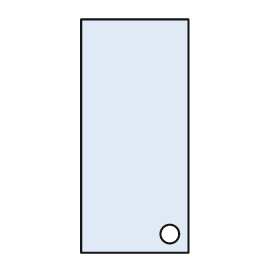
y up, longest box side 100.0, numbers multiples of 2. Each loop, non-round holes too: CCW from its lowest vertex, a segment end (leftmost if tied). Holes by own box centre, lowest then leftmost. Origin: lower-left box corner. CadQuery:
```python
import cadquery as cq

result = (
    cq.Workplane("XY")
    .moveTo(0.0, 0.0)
    .lineTo(46.0, 0.0)
    .lineTo(46.0, 100.0)
    .lineTo(0.0, 100.0)
    .close()
    .moveTo(38.0, 8.0)
    .circle(4.0)
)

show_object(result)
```